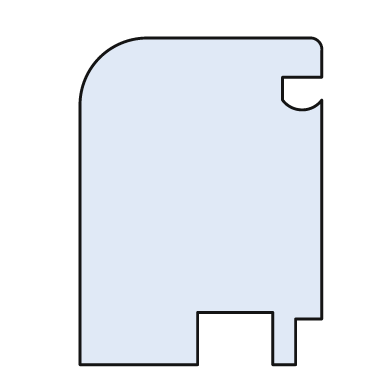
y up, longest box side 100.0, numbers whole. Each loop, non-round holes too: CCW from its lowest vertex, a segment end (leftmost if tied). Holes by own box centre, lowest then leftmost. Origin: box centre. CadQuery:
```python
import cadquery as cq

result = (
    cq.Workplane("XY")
    .moveTo(-37.0, -50.0)
    .lineTo(-1.0, -50.0)
    .lineTo(-1.0, -34.0)
    .lineTo(22.0, -34.0)
    .lineTo(22.0, -50.0)
    .lineTo(29.0, -50.0)
    .lineTo(29.0, -36.0)
    .lineTo(37.0, -36.0)
    .lineTo(37.0, 31.0)
    .threePointArc((31.0, 28.0), (25.0, 31.0))
    .lineTo(25.0, 38.0)
    .lineTo(37.0, 38.0)
    .lineTo(37.0, 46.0)
    .threePointArc((36.0, 49.0), (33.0, 50.0))
    .lineTo(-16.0, 50.0)
    .threePointArc((-31.0, 44.0), (-37.0, 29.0))
    .close()
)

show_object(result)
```